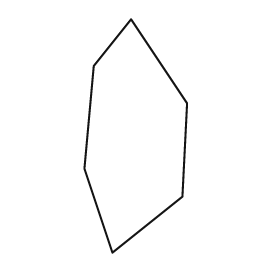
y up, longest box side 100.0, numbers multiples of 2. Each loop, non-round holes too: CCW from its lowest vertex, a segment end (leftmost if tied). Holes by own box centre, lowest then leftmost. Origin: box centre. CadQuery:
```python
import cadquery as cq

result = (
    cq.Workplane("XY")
    .moveTo(-10.0, -50.0)
    .lineTo(20.0, -26.0)
    .lineTo(22.0, 14.0)
    .lineTo(-2.0, 50.0)
    .lineTo(-18.0, 30.0)
    .lineTo(-22.0, -14.0)
    .close()
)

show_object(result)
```